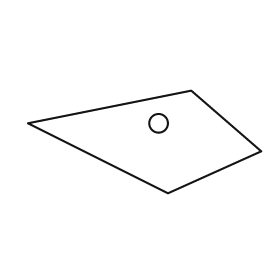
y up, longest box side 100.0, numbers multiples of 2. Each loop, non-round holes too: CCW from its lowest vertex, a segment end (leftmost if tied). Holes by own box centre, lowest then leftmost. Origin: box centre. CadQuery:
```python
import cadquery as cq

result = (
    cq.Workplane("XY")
    .moveTo(10.0, -22.0)
    .lineTo(50.0, -4.0)
    .lineTo(20.0, 22.0)
    .lineTo(-50.0, 8.0)
    .close()
    .moveTo(6.0, 8.0)
    .circle(4.0)
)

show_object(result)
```